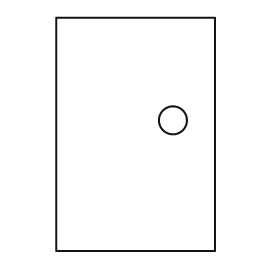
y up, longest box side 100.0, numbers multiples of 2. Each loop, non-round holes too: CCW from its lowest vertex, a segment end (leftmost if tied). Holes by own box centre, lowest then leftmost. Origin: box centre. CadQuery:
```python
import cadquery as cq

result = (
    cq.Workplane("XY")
    .moveTo(-34.0, -50.0)
    .lineTo(34.0, -50.0)
    .lineTo(34.0, 50.0)
    .lineTo(-34.0, 50.0)
    .close()
    .moveTo(16.0, 6.0)
    .circle(6.0)
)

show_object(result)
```